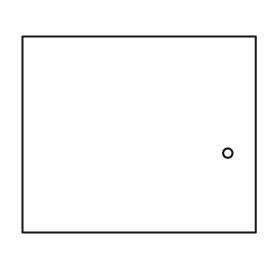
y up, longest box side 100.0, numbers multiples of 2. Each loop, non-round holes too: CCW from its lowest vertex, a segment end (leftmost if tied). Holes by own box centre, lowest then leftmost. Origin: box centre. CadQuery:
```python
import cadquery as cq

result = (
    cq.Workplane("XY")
    .moveTo(-50.0, -42.0)
    .lineTo(50.0, -42.0)
    .lineTo(50.0, 42.0)
    .lineTo(-50.0, 42.0)
    .close()
    .moveTo(38.0, -8.0)
    .circle(2.0)
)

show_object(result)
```